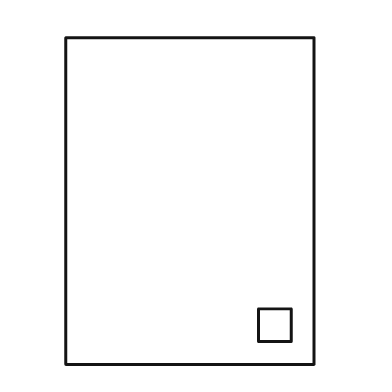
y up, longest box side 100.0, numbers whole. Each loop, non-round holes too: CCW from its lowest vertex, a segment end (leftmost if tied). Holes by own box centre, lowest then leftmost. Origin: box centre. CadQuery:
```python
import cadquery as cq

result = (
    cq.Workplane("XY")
    .moveTo(-38.0, -50.0)
    .lineTo(38.0, -50.0)
    .lineTo(38.0, 50.0)
    .lineTo(-38.0, 50.0)
    .close()
    .moveTo(21.0, -43.0)
    .lineTo(31.0, -43.0)
    .lineTo(31.0, -33.0)
    .lineTo(21.0, -33.0)
    .close()
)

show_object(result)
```